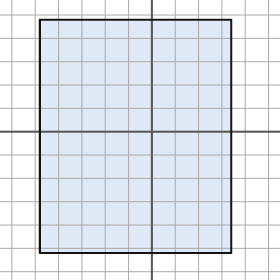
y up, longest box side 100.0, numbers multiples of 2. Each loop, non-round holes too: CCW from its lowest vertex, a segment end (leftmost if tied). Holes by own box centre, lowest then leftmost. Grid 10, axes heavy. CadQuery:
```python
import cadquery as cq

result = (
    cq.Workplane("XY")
    .moveTo(-48.0, -52.0)
    .lineTo(34.0, -52.0)
    .lineTo(34.0, 48.0)
    .lineTo(-48.0, 48.0)
    .close()
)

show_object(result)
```